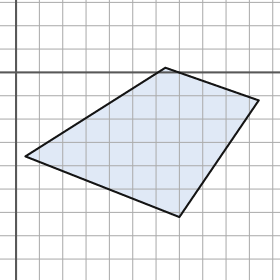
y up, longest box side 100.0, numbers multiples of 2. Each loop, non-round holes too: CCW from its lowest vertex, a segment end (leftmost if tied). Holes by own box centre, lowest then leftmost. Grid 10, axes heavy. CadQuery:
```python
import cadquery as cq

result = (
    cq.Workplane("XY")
    .moveTo(70.0, -62.0)
    .lineTo(104.0, -12.0)
    .lineTo(64.0, 2.0)
    .lineTo(4.0, -36.0)
    .close()
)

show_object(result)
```